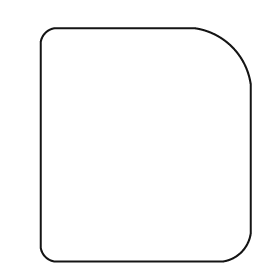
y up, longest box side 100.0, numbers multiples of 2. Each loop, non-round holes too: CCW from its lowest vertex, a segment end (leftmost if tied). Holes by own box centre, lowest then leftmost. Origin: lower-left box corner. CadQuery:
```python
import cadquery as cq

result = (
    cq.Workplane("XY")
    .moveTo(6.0, 0.0)
    .lineTo(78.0, 0.0)
    .threePointArc((86.0, 4.0), (90.0, 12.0))
    .lineTo(90.0, 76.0)
    .threePointArc((82.0, 92.0), (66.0, 100.0))
    .lineTo(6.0, 100.0)
    .threePointArc((2.0, 98.0), (0.0, 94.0))
    .lineTo(0.0, 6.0)
    .threePointArc((2.0, 2.0), (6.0, 0.0))
    .close()
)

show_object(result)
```